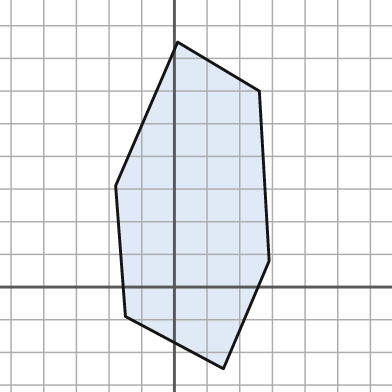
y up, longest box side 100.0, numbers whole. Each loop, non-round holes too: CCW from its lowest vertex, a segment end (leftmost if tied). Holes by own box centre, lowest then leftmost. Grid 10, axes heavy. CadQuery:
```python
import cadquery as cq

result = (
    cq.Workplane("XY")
    .moveTo(15.0, -25.0)
    .lineTo(29.0, 8.0)
    .lineTo(26.0, 60.0)
    .lineTo(1.0, 75.0)
    .lineTo(-18.0, 31.0)
    .lineTo(-15.0, -9.0)
    .close()
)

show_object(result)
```